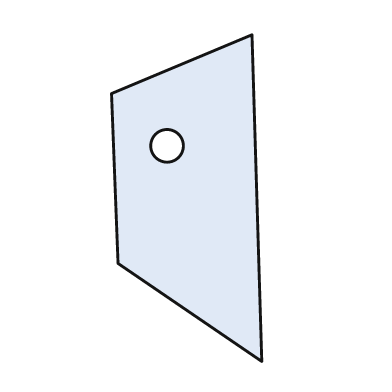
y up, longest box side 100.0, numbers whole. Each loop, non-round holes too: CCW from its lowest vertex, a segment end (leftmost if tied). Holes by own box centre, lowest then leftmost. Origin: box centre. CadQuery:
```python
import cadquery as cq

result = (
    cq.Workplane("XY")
    .moveTo(23.0, -50.0)
    .lineTo(20.0, 50.0)
    .lineTo(-23.0, 32.0)
    .lineTo(-21.0, -20.0)
    .close()
    .moveTo(-6.0, 16.0)
    .circle(5.0)
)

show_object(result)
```